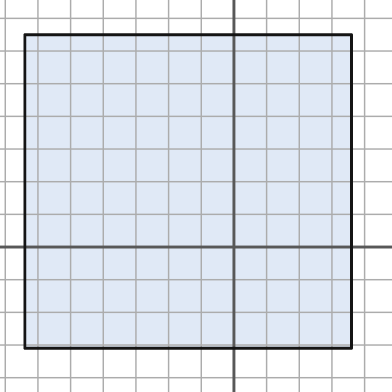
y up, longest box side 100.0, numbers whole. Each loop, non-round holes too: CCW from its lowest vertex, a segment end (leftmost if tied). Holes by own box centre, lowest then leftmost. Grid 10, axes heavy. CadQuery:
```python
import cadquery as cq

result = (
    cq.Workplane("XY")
    .moveTo(-64.0, -31.0)
    .lineTo(36.0, -31.0)
    .lineTo(36.0, 65.0)
    .lineTo(-64.0, 65.0)
    .close()
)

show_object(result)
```